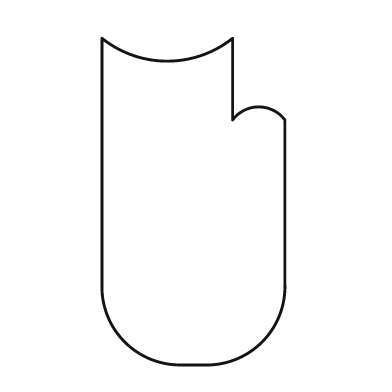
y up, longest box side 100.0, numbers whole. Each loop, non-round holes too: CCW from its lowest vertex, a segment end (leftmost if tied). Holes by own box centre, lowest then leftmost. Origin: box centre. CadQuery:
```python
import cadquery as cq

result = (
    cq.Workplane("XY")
    .moveTo(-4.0, -50.0)
    .lineTo(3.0, -50.0)
    .threePointArc((21.0, -43.0), (28.0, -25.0))
    .lineTo(28.0, 25.0)
    .threePointArc((20.0, 29.0), (12.0, 25.0))
    .lineTo(12.0, 50.0)
    .threePointArc((-8.0, 43.0), (-28.0, 50.0))
    .lineTo(-28.0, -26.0)
    .threePointArc((-21.0, -43.0), (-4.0, -50.0))
    .close()
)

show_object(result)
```